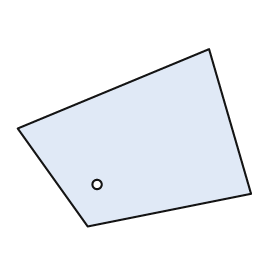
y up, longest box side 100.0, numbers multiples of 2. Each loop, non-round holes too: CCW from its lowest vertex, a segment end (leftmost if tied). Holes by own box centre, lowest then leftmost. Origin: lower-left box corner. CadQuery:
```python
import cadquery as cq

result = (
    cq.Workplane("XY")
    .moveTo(30.0, 0.0)
    .lineTo(100.0, 14.0)
    .lineTo(82.0, 76.0)
    .lineTo(0.0, 42.0)
    .close()
    .moveTo(34.0, 18.0)
    .circle(2.0)
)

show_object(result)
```